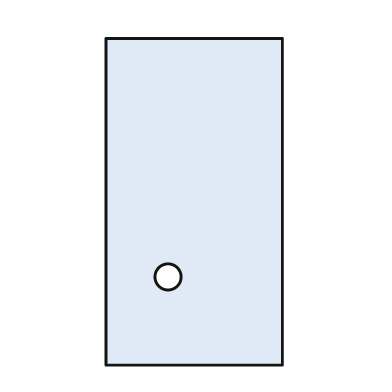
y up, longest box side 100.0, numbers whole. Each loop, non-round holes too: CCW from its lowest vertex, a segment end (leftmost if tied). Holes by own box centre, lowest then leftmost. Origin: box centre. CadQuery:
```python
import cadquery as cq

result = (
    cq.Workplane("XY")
    .moveTo(-27.0, -50.0)
    .lineTo(27.0, -50.0)
    .lineTo(27.0, 50.0)
    .lineTo(-27.0, 50.0)
    .close()
    .moveTo(-8.0, -23.0)
    .circle(4.0)
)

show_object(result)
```